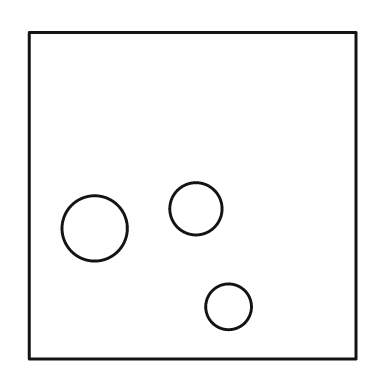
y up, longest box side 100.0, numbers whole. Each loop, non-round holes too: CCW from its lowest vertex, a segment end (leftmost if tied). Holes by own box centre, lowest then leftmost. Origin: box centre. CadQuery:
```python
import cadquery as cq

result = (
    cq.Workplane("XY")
    .moveTo(-50.0, -50.0)
    .lineTo(50.0, -50.0)
    .lineTo(50.0, 50.0)
    .lineTo(-50.0, 50.0)
    .close()
    .moveTo(11.0, -34.0)
    .circle(7.0)
    .moveTo(-30.0, -10.0)
    .circle(10.0)
    .moveTo(1.0, -4.0)
    .circle(8.0)
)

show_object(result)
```